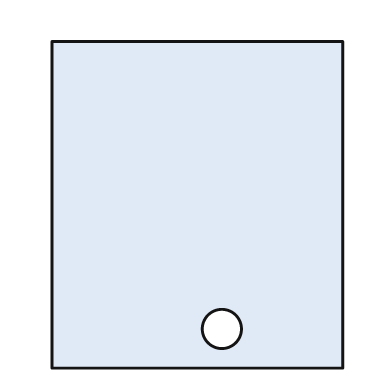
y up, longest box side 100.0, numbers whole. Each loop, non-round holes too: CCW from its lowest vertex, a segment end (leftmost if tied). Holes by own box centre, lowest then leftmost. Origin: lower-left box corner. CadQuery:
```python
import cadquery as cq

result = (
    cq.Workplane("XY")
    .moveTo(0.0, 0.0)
    .lineTo(89.0, 0.0)
    .lineTo(89.0, 100.0)
    .lineTo(0.0, 100.0)
    .close()
    .moveTo(52.0, 12.0)
    .circle(6.0)
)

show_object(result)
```